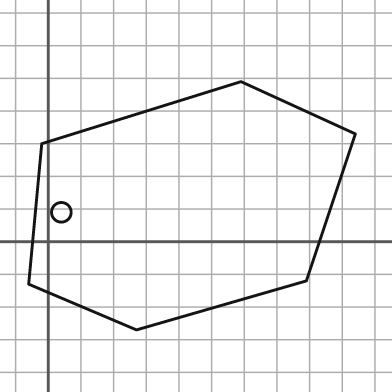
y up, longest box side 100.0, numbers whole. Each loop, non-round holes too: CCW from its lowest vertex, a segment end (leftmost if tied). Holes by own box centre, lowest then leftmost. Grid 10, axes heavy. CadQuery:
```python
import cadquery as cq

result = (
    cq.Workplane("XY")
    .moveTo(27.0, -27.0)
    .lineTo(79.0, -12.0)
    .lineTo(94.0, 33.0)
    .lineTo(59.0, 49.0)
    .lineTo(-2.0, 30.0)
    .lineTo(-6.0, -13.0)
    .close()
    .moveTo(4.0, 9.0)
    .circle(3.0)
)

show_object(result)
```